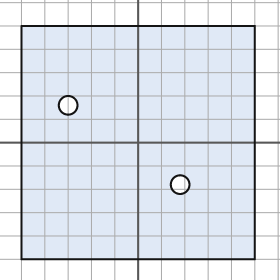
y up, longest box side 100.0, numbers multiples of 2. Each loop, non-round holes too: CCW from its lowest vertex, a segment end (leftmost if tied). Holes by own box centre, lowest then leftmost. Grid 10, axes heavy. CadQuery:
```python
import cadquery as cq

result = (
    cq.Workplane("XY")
    .moveTo(-50.0, -50.0)
    .lineTo(50.0, -50.0)
    .lineTo(50.0, 50.0)
    .lineTo(-50.0, 50.0)
    .close()
    .moveTo(18.0, -18.0)
    .circle(4.0)
    .moveTo(-30.0, 16.0)
    .circle(4.0)
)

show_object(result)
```